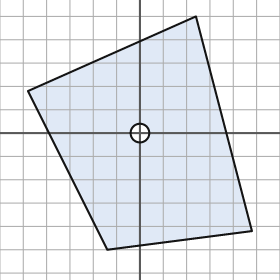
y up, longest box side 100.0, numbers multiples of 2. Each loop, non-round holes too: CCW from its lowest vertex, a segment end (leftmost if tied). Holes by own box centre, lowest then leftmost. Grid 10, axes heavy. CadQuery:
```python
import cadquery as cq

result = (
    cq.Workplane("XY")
    .moveTo(-14.0, -50.0)
    .lineTo(48.0, -42.0)
    .lineTo(24.0, 50.0)
    .lineTo(-48.0, 18.0)
    .close()
    .moveTo(0.0, 0.0)
    .circle(4.0)
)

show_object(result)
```